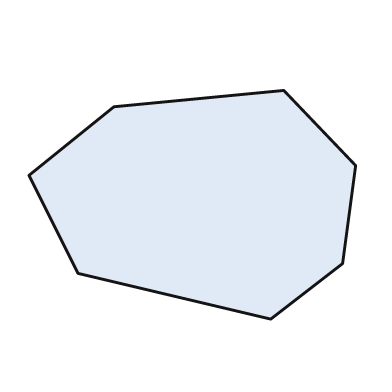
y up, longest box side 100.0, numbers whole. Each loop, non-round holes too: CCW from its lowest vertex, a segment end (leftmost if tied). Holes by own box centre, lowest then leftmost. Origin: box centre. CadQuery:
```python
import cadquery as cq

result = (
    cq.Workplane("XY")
    .moveTo(24.0, -35.0)
    .lineTo(46.0, -18.0)
    .lineTo(50.0, 12.0)
    .lineTo(28.0, 35.0)
    .lineTo(-24.0, 30.0)
    .lineTo(-50.0, 9.0)
    .lineTo(-35.0, -21.0)
    .close()
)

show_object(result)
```